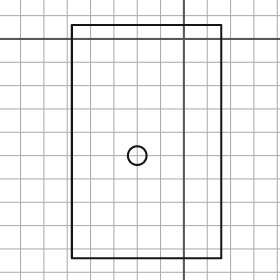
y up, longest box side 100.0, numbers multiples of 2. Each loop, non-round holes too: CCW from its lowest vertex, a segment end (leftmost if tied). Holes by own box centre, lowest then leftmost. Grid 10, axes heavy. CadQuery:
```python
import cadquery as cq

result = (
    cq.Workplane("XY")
    .moveTo(-48.0, -94.0)
    .lineTo(16.0, -94.0)
    .lineTo(16.0, 6.0)
    .lineTo(-48.0, 6.0)
    .close()
    .moveTo(-20.0, -50.0)
    .circle(4.0)
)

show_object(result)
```